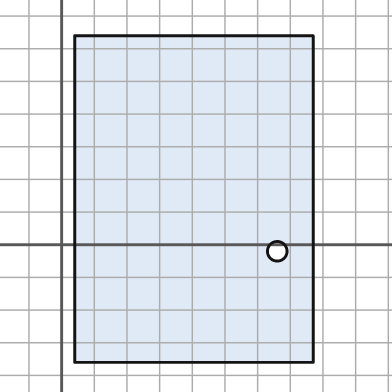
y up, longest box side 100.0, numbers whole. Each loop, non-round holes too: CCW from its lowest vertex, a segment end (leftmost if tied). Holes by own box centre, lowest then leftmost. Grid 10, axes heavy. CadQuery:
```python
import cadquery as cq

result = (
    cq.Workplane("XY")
    .moveTo(4.0, -36.0)
    .lineTo(77.0, -36.0)
    .lineTo(77.0, 64.0)
    .lineTo(4.0, 64.0)
    .close()
    .moveTo(66.0, -2.0)
    .circle(3.0)
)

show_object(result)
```